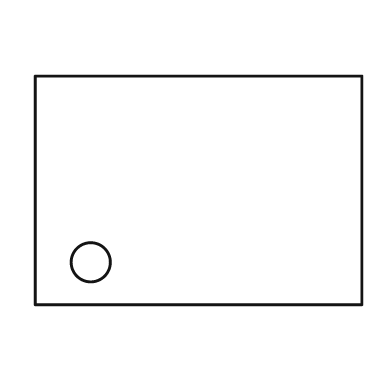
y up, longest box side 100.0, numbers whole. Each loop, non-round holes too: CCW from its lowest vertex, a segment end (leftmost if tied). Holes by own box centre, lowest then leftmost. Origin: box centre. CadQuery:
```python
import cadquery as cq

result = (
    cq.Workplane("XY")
    .moveTo(-50.0, -35.0)
    .lineTo(50.0, -35.0)
    .lineTo(50.0, 35.0)
    .lineTo(-50.0, 35.0)
    .close()
    .moveTo(-33.0, -22.0)
    .circle(6.0)
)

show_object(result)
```